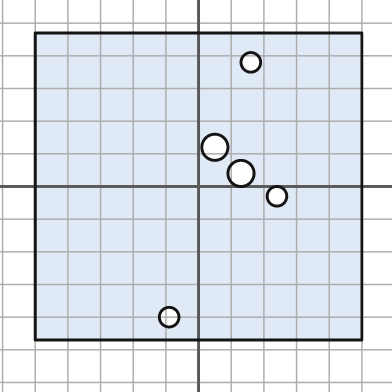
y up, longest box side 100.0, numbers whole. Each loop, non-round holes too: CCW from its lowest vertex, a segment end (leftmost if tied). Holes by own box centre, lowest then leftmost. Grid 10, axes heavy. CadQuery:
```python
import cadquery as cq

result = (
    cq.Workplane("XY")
    .moveTo(-50.0, -47.0)
    .lineTo(50.0, -47.0)
    .lineTo(50.0, 47.0)
    .lineTo(-50.0, 47.0)
    .close()
    .moveTo(-9.0, -40.0)
    .circle(3.0)
    .moveTo(24.0, -3.0)
    .circle(3.0)
    .moveTo(13.0, 4.0)
    .circle(4.0)
    .moveTo(5.0, 12.0)
    .circle(4.0)
    .moveTo(16.0, 38.0)
    .circle(3.0)
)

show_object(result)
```